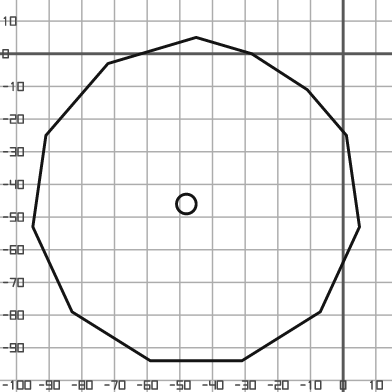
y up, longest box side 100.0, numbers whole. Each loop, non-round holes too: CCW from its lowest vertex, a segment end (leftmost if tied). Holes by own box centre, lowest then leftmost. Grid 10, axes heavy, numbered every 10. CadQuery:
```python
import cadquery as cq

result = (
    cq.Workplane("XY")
    .moveTo(-59.0, -94.0)
    .lineTo(-31.0, -94.0)
    .lineTo(-7.0, -79.0)
    .lineTo(5.0, -53.0)
    .lineTo(1.0, -25.0)
    .lineTo(-11.0, -11.0)
    .lineTo(-28.0, 0.0)
    .lineTo(-45.0, 5.0)
    .lineTo(-72.0, -3.0)
    .lineTo(-91.0, -25.0)
    .lineTo(-95.0, -53.0)
    .lineTo(-83.0, -79.0)
    .close()
    .moveTo(-48.0, -46.0)
    .circle(3.0)
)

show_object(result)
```